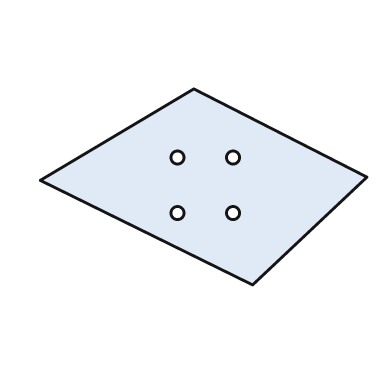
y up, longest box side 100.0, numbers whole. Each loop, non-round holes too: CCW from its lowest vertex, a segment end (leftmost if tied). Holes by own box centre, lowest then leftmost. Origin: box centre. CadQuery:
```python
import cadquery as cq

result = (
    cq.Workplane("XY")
    .moveTo(15.0, -30.0)
    .lineTo(50.0, 3.0)
    .lineTo(-3.0, 30.0)
    .lineTo(-50.0, 2.0)
    .close()
    .moveTo(-8.0, -8.0)
    .circle(2.0)
    .moveTo(9.0, -8.0)
    .circle(2.0)
    .moveTo(-8.0, 9.0)
    .circle(2.0)
    .moveTo(9.0, 9.0)
    .circle(2.0)
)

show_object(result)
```